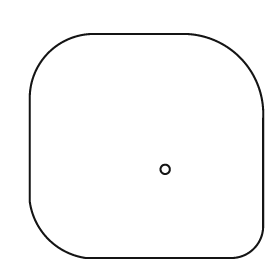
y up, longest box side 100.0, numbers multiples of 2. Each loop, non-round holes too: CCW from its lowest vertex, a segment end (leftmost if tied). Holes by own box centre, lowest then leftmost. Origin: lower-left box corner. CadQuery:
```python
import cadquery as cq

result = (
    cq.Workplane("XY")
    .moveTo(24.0, 0.0)
    .lineTo(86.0, 0.0)
    .threePointArc((96.0, 4.0), (100.0, 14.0))
    .lineTo(100.0, 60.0)
    .threePointArc((90.0, 86.0), (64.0, 96.0))
    .lineTo(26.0, 96.0)
    .threePointArc((8.0, 88.0), (0.0, 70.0))
    .lineTo(0.0, 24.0)
    .threePointArc((8.0, 8.0), (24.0, 0.0))
    .close()
    .moveTo(58.0, 38.0)
    .circle(2.0)
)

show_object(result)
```